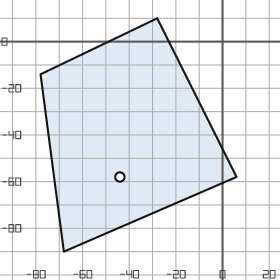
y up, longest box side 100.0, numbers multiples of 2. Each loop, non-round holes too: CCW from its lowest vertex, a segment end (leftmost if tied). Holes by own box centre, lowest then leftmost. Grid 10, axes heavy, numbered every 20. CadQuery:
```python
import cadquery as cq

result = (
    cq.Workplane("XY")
    .moveTo(-68.0, -90.0)
    .lineTo(6.0, -58.0)
    .lineTo(-28.0, 10.0)
    .lineTo(-78.0, -14.0)
    .close()
    .moveTo(-44.0, -58.0)
    .circle(2.0)
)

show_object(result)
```